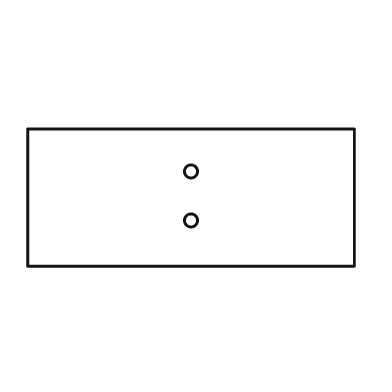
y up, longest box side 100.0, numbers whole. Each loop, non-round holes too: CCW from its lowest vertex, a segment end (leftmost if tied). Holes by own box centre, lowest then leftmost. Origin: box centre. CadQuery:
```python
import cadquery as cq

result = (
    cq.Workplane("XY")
    .moveTo(-50.0, -21.0)
    .lineTo(50.0, -21.0)
    .lineTo(50.0, 21.0)
    .lineTo(-50.0, 21.0)
    .close()
    .moveTo(0.0, -7.0)
    .circle(2.0)
    .moveTo(0.0, 8.0)
    .circle(2.0)
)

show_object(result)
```